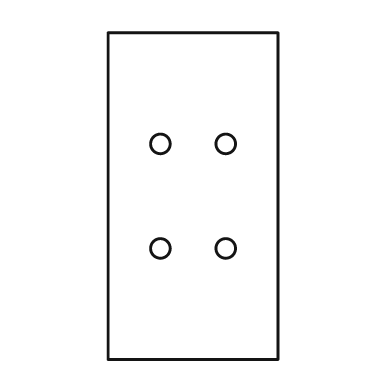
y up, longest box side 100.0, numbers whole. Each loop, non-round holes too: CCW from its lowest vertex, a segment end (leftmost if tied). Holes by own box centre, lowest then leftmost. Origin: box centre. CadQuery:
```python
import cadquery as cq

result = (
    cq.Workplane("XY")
    .moveTo(-26.0, -50.0)
    .lineTo(26.0, -50.0)
    .lineTo(26.0, 50.0)
    .lineTo(-26.0, 50.0)
    .close()
    .moveTo(-10.0, -16.0)
    .circle(3.0)
    .moveTo(10.0, -16.0)
    .circle(3.0)
    .moveTo(-10.0, 16.0)
    .circle(3.0)
    .moveTo(10.0, 16.0)
    .circle(3.0)
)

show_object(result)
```